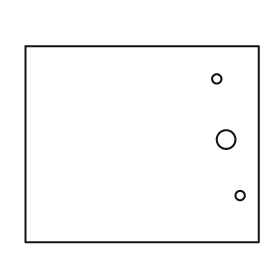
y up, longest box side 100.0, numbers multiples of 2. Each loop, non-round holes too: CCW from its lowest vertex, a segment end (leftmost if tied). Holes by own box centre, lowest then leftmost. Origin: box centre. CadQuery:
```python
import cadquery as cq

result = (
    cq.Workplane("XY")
    .moveTo(-50.0, -42.0)
    .lineTo(50.0, -42.0)
    .lineTo(50.0, 42.0)
    .lineTo(-50.0, 42.0)
    .close()
    .moveTo(42.0, -22.0)
    .circle(2.0)
    .moveTo(36.0, 2.0)
    .circle(4.0)
    .moveTo(32.0, 28.0)
    .circle(2.0)
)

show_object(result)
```